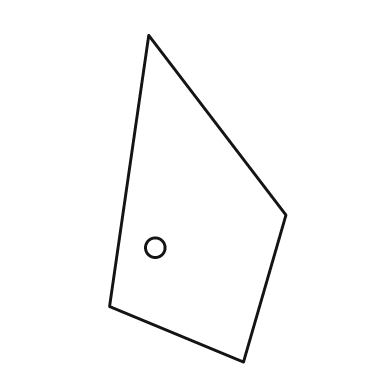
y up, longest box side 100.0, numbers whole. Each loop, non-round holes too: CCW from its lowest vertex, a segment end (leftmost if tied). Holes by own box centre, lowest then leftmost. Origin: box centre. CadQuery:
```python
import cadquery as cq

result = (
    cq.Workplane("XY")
    .moveTo(14.0, -50.0)
    .lineTo(27.0, -5.0)
    .lineTo(-15.0, 50.0)
    .lineTo(-27.0, -33.0)
    .close()
    .moveTo(-13.0, -15.0)
    .circle(3.0)
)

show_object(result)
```